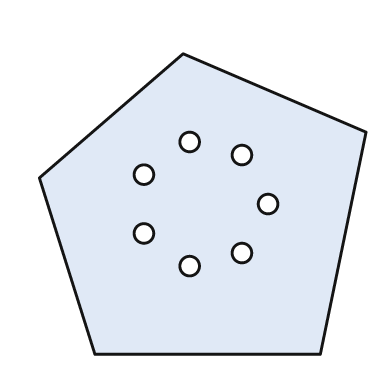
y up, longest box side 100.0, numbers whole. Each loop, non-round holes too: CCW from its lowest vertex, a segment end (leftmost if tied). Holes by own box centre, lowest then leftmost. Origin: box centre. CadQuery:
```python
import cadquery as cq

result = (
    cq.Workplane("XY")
    .moveTo(-33.0, -46.0)
    .lineTo(36.0, -46.0)
    .lineTo(50.0, 22.0)
    .lineTo(-6.0, 46.0)
    .lineTo(-50.0, 8.0)
    .close()
    .moveTo(-4.0, -19.0)
    .circle(3.0)
    .moveTo(12.0, -15.0)
    .circle(3.0)
    .moveTo(-18.0, -9.0)
    .circle(3.0)
    .moveTo(20.0, 0.0)
    .circle(3.0)
    .moveTo(-18.0, 9.0)
    .circle(3.0)
    .moveTo(12.0, 15.0)
    .circle(3.0)
    .moveTo(-4.0, 19.0)
    .circle(3.0)
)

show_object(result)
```